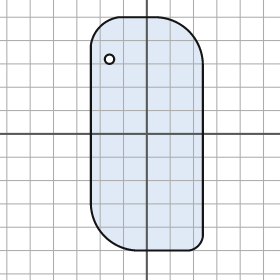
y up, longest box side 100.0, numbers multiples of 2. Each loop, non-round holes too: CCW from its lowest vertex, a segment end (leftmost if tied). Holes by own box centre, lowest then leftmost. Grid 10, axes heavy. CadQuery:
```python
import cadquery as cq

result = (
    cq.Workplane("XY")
    .moveTo(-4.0, -50.0)
    .lineTo(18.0, -50.0)
    .threePointArc((22.0, -48.0), (24.0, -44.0))
    .lineTo(24.0, 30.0)
    .threePointArc((18.0, 44.0), (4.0, 50.0))
    .lineTo(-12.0, 50.0)
    .threePointArc((-20.0, 46.0), (-24.0, 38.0))
    .lineTo(-24.0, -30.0)
    .threePointArc((-18.0, -44.0), (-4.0, -50.0))
    .close()
    .moveTo(-16.0, 32.0)
    .circle(2.0)
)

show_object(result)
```